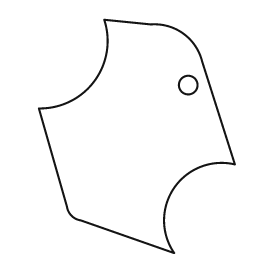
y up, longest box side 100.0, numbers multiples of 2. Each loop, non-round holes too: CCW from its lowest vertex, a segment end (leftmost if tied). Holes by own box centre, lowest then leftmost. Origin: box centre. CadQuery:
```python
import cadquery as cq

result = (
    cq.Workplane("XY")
    .moveTo(16.0, -50.0)
    .threePointArc((16.0, -22.0), (42.0, -12.0))
    .lineTo(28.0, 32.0)
    .threePointArc((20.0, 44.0), (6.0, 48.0))
    .lineTo(-14.0, 50.0)
    .threePointArc((-18.0, 24.0), (-42.0, 12.0))
    .lineTo(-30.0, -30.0)
    .threePointArc((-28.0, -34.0), (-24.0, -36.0))
    .close()
    .moveTo(22.0, 22.0)
    .circle(4.0)
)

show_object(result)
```